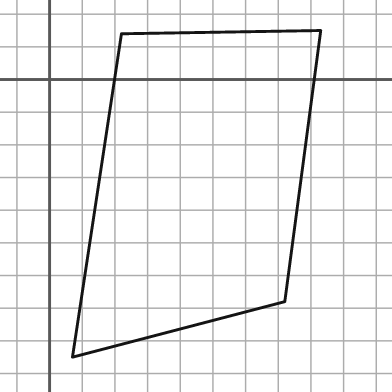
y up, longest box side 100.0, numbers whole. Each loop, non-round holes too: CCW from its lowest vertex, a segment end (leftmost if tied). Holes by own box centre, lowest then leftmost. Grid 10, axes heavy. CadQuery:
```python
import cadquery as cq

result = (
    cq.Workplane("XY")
    .moveTo(7.0, -85.0)
    .lineTo(72.0, -68.0)
    .lineTo(83.0, 15.0)
    .lineTo(22.0, 14.0)
    .close()
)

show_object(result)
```